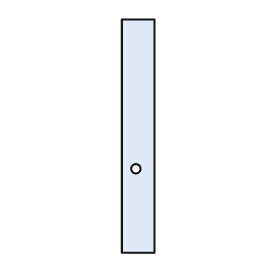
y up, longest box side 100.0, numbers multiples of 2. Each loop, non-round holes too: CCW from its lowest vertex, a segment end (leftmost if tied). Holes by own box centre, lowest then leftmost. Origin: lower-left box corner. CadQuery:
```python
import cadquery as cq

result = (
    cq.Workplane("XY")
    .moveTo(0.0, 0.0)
    .lineTo(14.0, 0.0)
    .lineTo(14.0, 100.0)
    .lineTo(0.0, 100.0)
    .close()
    .moveTo(6.0, 36.0)
    .circle(2.0)
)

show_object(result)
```